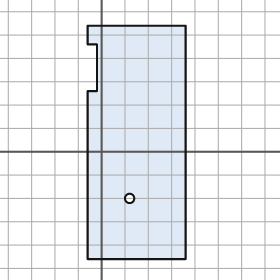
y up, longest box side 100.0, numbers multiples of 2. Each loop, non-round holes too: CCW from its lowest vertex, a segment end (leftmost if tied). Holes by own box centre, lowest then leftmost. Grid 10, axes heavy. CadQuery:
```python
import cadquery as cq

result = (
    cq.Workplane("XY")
    .moveTo(-6.0, -46.0)
    .lineTo(36.0, -46.0)
    .lineTo(36.0, 54.0)
    .lineTo(-6.0, 54.0)
    .lineTo(-6.0, 46.0)
    .lineTo(-2.0, 46.0)
    .lineTo(-2.0, 26.0)
    .lineTo(-6.0, 26.0)
    .close()
    .moveTo(12.0, -20.0)
    .circle(2.0)
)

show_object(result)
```